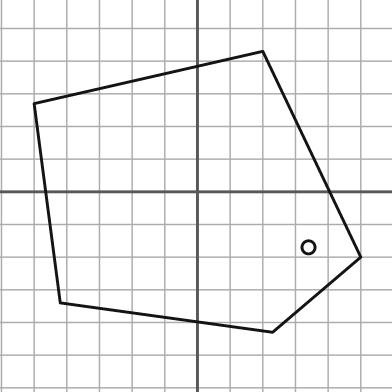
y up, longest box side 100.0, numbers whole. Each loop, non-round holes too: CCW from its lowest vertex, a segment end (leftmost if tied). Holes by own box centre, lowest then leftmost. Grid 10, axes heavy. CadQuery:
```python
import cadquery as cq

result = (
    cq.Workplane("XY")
    .moveTo(23.0, -43.0)
    .lineTo(50.0, -20.0)
    .lineTo(20.0, 43.0)
    .lineTo(-50.0, 27.0)
    .lineTo(-42.0, -34.0)
    .close()
    .moveTo(34.0, -17.0)
    .circle(2.0)
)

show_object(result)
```